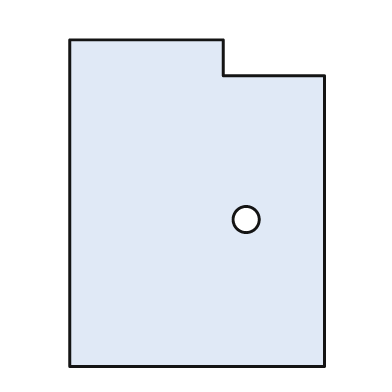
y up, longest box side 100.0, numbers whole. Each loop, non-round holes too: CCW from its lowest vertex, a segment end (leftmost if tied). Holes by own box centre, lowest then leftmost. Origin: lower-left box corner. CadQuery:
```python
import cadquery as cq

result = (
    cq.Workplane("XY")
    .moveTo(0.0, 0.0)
    .lineTo(78.0, 0.0)
    .lineTo(78.0, 89.0)
    .lineTo(47.0, 89.0)
    .lineTo(47.0, 100.0)
    .lineTo(0.0, 100.0)
    .close()
    .moveTo(54.0, 45.0)
    .circle(4.0)
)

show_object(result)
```